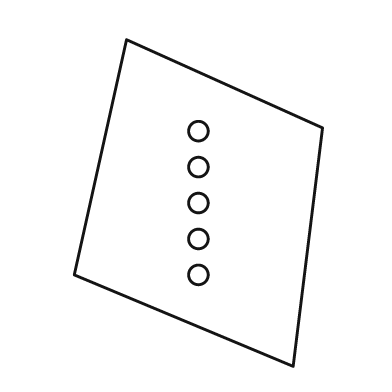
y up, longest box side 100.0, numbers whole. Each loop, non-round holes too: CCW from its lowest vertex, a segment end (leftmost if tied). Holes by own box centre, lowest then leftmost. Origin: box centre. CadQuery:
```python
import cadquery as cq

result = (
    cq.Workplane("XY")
    .moveTo(29.0, -50.0)
    .lineTo(38.0, 23.0)
    .lineTo(-22.0, 50.0)
    .lineTo(-38.0, -22.0)
    .close()
    .moveTo(0.0, -22.0)
    .circle(3.0)
    .moveTo(0.0, -11.0)
    .circle(3.0)
    .moveTo(0.0, 0.0)
    .circle(3.0)
    .moveTo(0.0, 11.0)
    .circle(3.0)
    .moveTo(0.0, 22.0)
    .circle(3.0)
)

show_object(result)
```